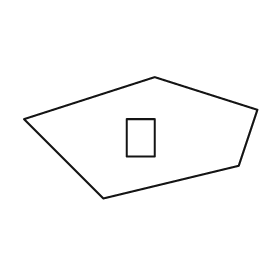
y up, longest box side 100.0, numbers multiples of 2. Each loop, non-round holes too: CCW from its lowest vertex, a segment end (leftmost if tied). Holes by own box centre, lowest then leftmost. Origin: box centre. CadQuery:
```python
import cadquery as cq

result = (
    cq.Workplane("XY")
    .moveTo(-16.0, -26.0)
    .lineTo(42.0, -12.0)
    .lineTo(50.0, 12.0)
    .lineTo(6.0, 26.0)
    .lineTo(-50.0, 8.0)
    .close()
    .moveTo(-6.0, -8.0)
    .lineTo(6.0, -8.0)
    .lineTo(6.0, 8.0)
    .lineTo(-6.0, 8.0)
    .close()
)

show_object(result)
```